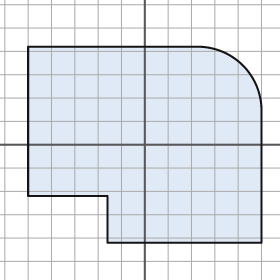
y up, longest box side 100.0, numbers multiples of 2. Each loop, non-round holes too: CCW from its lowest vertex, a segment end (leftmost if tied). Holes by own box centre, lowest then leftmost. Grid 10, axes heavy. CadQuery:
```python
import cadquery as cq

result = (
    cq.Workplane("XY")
    .moveTo(-16.0, -42.0)
    .lineTo(50.0, -42.0)
    .lineTo(50.0, 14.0)
    .threePointArc((42.0, 34.0), (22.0, 42.0))
    .lineTo(-50.0, 42.0)
    .lineTo(-50.0, -22.0)
    .lineTo(-16.0, -22.0)
    .close()
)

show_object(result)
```